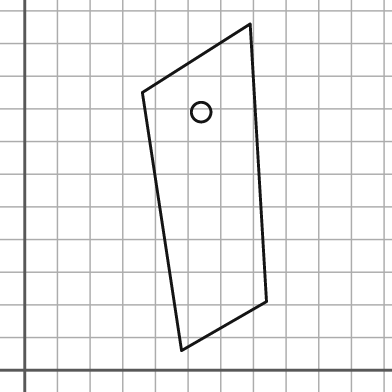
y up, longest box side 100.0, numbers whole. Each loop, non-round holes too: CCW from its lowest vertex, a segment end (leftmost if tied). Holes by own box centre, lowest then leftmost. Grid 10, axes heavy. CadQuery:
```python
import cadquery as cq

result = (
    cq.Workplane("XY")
    .moveTo(48.0, 6.0)
    .lineTo(74.0, 21.0)
    .lineTo(69.0, 106.0)
    .lineTo(36.0, 85.0)
    .close()
    .moveTo(54.0, 79.0)
    .circle(3.0)
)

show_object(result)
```